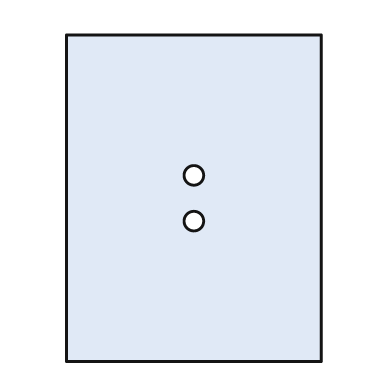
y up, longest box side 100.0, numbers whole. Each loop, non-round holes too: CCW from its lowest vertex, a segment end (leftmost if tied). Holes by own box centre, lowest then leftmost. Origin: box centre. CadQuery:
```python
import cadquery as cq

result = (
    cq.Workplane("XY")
    .moveTo(-39.0, -50.0)
    .lineTo(39.0, -50.0)
    .lineTo(39.0, 50.0)
    .lineTo(-39.0, 50.0)
    .close()
    .moveTo(0.0, -7.0)
    .circle(3.0)
    .moveTo(0.0, 7.0)
    .circle(3.0)
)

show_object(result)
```